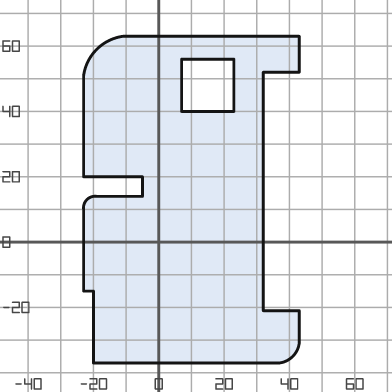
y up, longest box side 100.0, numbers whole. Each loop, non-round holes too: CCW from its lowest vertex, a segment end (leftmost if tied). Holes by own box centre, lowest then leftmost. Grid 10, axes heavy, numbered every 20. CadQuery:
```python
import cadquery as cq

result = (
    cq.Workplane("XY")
    .moveTo(-20.0, -37.0)
    .lineTo(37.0, -37.0)
    .threePointArc((41.0, -35.0), (43.0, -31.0))
    .lineTo(43.0, -21.0)
    .lineTo(32.0, -21.0)
    .lineTo(32.0, 52.0)
    .lineTo(43.0, 52.0)
    .lineTo(43.0, 63.0)
    .lineTo(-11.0, 63.0)
    .threePointArc((-19.0, 59.0), (-23.0, 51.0))
    .lineTo(-23.0, 20.0)
    .lineTo(-5.0, 20.0)
    .lineTo(-5.0, 14.0)
    .lineTo(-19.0, 14.0)
    .threePointArc((-22.0, 13.0), (-23.0, 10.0))
    .lineTo(-23.0, -15.0)
    .lineTo(-20.0, -15.0)
    .close()
    .moveTo(7.0, 40.0)
    .lineTo(23.0, 40.0)
    .lineTo(23.0, 56.0)
    .lineTo(7.0, 56.0)
    .close()
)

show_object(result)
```